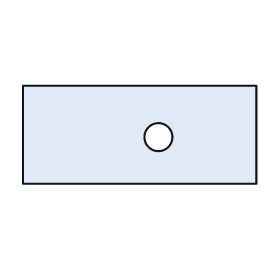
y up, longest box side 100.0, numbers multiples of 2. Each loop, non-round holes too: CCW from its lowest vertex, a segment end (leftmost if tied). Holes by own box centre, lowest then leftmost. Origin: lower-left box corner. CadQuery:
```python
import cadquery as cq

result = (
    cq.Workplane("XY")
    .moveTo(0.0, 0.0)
    .lineTo(100.0, 0.0)
    .lineTo(100.0, 42.0)
    .lineTo(0.0, 42.0)
    .close()
    .moveTo(58.0, 20.0)
    .circle(6.0)
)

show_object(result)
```